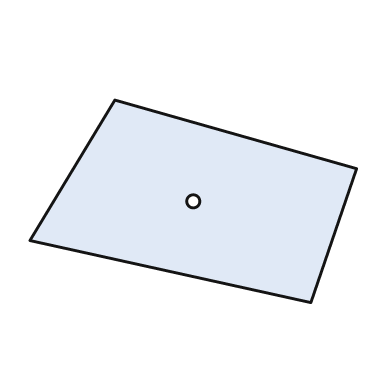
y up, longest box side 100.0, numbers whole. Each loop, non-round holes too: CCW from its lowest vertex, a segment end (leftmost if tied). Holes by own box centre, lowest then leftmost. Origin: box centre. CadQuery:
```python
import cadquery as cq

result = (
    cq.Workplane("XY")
    .moveTo(36.0, -31.0)
    .lineTo(50.0, 10.0)
    .lineTo(-24.0, 31.0)
    .lineTo(-50.0, -12.0)
    .close()
    .moveTo(0.0, 0.0)
    .circle(2.0)
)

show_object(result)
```